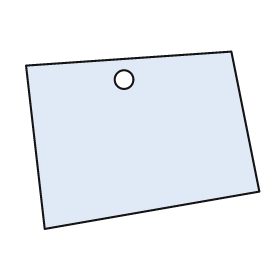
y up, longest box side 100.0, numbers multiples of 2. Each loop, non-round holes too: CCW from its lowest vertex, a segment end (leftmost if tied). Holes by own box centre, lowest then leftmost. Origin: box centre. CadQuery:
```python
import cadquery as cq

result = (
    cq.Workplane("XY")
    .moveTo(-42.0, -38.0)
    .lineTo(50.0, -22.0)
    .lineTo(38.0, 38.0)
    .lineTo(-50.0, 32.0)
    .close()
    .moveTo(-8.0, 26.0)
    .circle(4.0)
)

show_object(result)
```